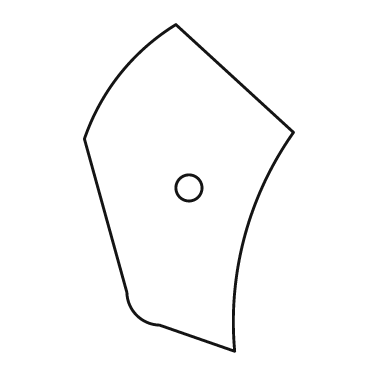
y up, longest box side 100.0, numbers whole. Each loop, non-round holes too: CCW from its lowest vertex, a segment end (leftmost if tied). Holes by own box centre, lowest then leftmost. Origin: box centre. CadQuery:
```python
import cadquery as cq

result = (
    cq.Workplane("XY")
    .moveTo(14.0, -50.0)
    .threePointArc((17.0, -15.0), (32.0, 17.0))
    .lineTo(-4.0, 50.0)
    .threePointArc((-21.0, 35.0), (-32.0, 15.0))
    .lineTo(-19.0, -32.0)
    .threePointArc((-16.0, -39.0), (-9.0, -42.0))
    .close()
    .moveTo(0.0, 0.0)
    .circle(4.0)
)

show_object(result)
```